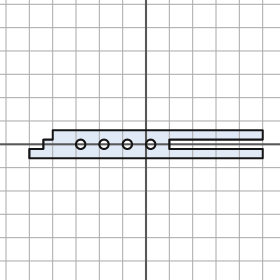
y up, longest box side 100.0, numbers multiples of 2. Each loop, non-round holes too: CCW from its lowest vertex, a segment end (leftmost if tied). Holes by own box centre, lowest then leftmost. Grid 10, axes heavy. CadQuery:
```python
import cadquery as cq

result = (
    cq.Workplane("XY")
    .moveTo(-50.0, -6.0)
    .lineTo(50.0, -6.0)
    .lineTo(50.0, -2.0)
    .lineTo(10.0, -2.0)
    .lineTo(10.0, 2.0)
    .lineTo(50.0, 2.0)
    .lineTo(50.0, 6.0)
    .lineTo(-40.0, 6.0)
    .lineTo(-40.0, 2.0)
    .lineTo(-44.0, 2.0)
    .lineTo(-44.0, -2.0)
    .lineTo(-50.0, -2.0)
    .close()
    .moveTo(-28.0, 0.0)
    .circle(2.0)
    .moveTo(-18.0, 0.0)
    .circle(2.0)
    .moveTo(-8.0, 0.0)
    .circle(2.0)
    .moveTo(2.0, 0.0)
    .circle(2.0)
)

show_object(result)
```